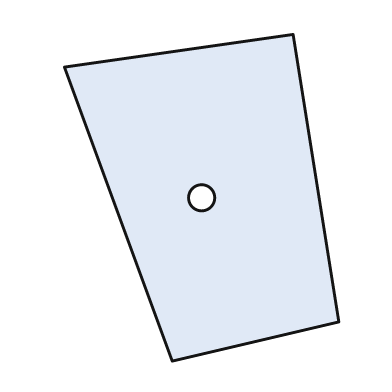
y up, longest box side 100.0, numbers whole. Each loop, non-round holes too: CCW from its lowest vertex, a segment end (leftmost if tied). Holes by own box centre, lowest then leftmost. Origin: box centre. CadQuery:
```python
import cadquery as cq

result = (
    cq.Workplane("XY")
    .moveTo(-9.0, -50.0)
    .lineTo(42.0, -38.0)
    .lineTo(28.0, 50.0)
    .lineTo(-42.0, 40.0)
    .close()
    .moveTo(0.0, 0.0)
    .circle(4.0)
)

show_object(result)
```